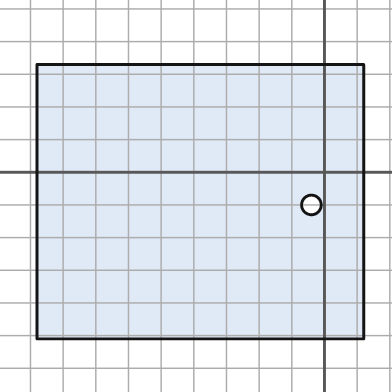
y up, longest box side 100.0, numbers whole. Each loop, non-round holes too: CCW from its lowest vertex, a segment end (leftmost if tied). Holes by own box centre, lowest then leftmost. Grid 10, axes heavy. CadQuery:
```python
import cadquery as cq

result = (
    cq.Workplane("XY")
    .moveTo(-88.0, -51.0)
    .lineTo(12.0, -51.0)
    .lineTo(12.0, 33.0)
    .lineTo(-88.0, 33.0)
    .close()
    .moveTo(-4.0, -10.0)
    .circle(3.0)
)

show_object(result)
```